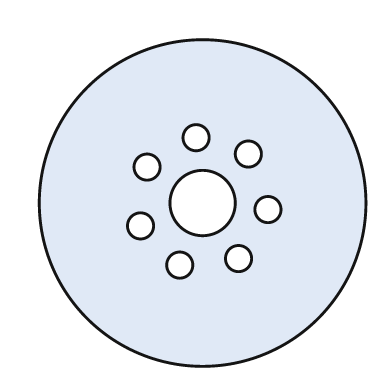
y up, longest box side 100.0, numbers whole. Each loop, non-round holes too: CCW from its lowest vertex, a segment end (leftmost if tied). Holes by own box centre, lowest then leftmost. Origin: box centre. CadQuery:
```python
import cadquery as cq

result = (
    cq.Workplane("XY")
    .moveTo(0.0, 0.0)
    .circle(50.0)
    .moveTo(-7.0, -19.0)
    .circle(4.0)
    .moveTo(11.0, -17.0)
    .circle(4.0)
    .moveTo(-19.0, -7.0)
    .circle(4.0)
    .moveTo(20.0, -2.0)
    .circle(4.0)
    .moveTo(0.0, 0.0)
    .circle(10.0)
    .moveTo(-17.0, 11.0)
    .circle(4.0)
    .moveTo(14.0, 15.0)
    .circle(4.0)
    .moveTo(-2.0, 20.0)
    .circle(4.0)
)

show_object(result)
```